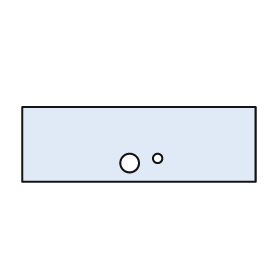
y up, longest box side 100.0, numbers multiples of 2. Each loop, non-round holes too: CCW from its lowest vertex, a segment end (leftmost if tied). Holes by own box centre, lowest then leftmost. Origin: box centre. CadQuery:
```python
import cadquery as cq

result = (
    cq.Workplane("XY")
    .moveTo(-50.0, -16.0)
    .lineTo(50.0, -16.0)
    .lineTo(50.0, 16.0)
    .lineTo(-50.0, 16.0)
    .close()
    .moveTo(-4.0, -8.0)
    .circle(4.0)
    .moveTo(8.0, -6.0)
    .circle(2.0)
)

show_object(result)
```